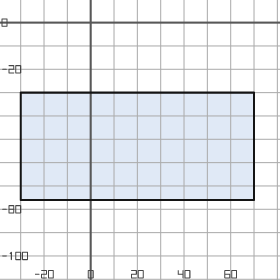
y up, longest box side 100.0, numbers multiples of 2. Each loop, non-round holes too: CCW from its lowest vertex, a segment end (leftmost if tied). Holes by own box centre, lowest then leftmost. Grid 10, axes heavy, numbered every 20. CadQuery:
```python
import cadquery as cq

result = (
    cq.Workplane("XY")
    .moveTo(-30.0, -76.0)
    .lineTo(70.0, -76.0)
    .lineTo(70.0, -30.0)
    .lineTo(-30.0, -30.0)
    .close()
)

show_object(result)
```